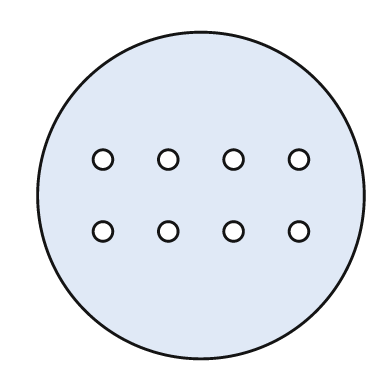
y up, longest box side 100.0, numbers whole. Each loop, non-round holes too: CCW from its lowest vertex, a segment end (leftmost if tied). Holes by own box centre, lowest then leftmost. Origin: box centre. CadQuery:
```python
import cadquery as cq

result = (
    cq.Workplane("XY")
    .moveTo(0.0, 0.0)
    .circle(50.0)
    .moveTo(-30.0, -11.0)
    .circle(3.0)
    .moveTo(-10.0, -11.0)
    .circle(3.0)
    .moveTo(10.0, -11.0)
    .circle(3.0)
    .moveTo(30.0, -11.0)
    .circle(3.0)
    .moveTo(-30.0, 11.0)
    .circle(3.0)
    .moveTo(-10.0, 11.0)
    .circle(3.0)
    .moveTo(10.0, 11.0)
    .circle(3.0)
    .moveTo(30.0, 11.0)
    .circle(3.0)
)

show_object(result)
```